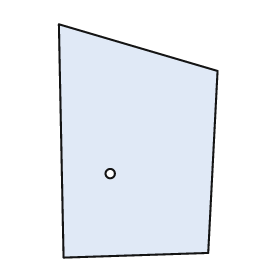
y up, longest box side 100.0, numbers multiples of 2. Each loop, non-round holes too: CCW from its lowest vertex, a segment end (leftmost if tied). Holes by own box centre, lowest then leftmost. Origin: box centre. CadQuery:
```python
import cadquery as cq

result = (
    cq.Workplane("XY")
    .moveTo(-32.0, -50.0)
    .lineTo(30.0, -48.0)
    .lineTo(34.0, 30.0)
    .lineTo(-34.0, 50.0)
    .close()
    .moveTo(-12.0, -14.0)
    .circle(2.0)
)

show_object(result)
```